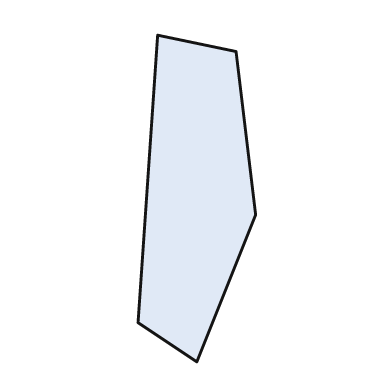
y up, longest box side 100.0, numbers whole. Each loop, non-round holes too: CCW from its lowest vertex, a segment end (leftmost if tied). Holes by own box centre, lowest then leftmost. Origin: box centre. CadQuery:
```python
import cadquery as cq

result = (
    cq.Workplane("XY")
    .moveTo(0.0, -50.0)
    .lineTo(18.0, -5.0)
    .lineTo(12.0, 45.0)
    .lineTo(-12.0, 50.0)
    .lineTo(-18.0, -38.0)
    .close()
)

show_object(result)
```